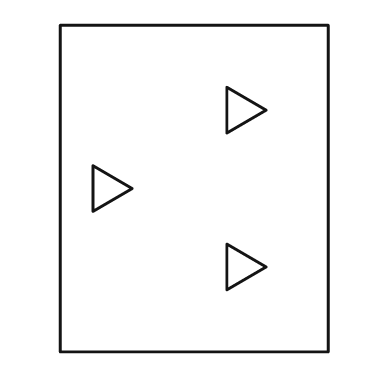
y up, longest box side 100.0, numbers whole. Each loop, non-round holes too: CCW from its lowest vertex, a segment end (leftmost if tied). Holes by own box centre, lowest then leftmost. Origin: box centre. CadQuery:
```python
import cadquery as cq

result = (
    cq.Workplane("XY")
    .moveTo(-41.0, -50.0)
    .lineTo(41.0, -50.0)
    .lineTo(41.0, 50.0)
    .lineTo(-41.0, 50.0)
    .close()
    .moveTo(10.0, -31.0)
    .lineTo(22.0, -24.0)
    .lineTo(10.0, -17.0)
    .close()
    .moveTo(-31.0, -7.0)
    .lineTo(-19.0, 0.0)
    .lineTo(-31.0, 7.0)
    .close()
    .moveTo(10.0, 17.0)
    .lineTo(22.0, 24.0)
    .lineTo(10.0, 31.0)
    .close()
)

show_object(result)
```